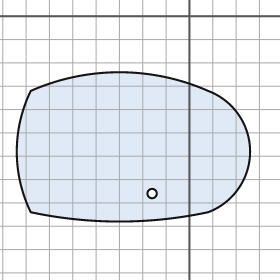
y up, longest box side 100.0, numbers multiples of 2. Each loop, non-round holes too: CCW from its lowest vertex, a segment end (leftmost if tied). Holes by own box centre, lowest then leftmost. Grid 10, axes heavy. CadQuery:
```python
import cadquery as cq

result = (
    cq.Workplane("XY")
    .moveTo(-68.0, -84.0)
    .threePointArc((-30.0, -88.0), (8.0, -84.0))
    .threePointArc((26.0, -58.0), (8.0, -32.0))
    .threePointArc((-30.0, -24.0), (-68.0, -32.0))
    .threePointArc((-74.0, -58.0), (-68.0, -84.0))
    .close()
    .moveTo(-16.0, -76.0)
    .circle(2.0)
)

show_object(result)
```